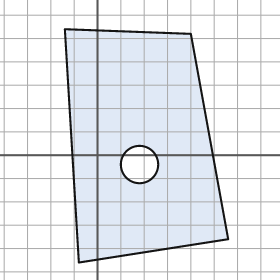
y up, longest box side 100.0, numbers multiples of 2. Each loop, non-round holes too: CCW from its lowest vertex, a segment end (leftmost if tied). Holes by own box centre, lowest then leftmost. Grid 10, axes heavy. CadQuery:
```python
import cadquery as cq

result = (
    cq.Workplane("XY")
    .moveTo(-8.0, -46.0)
    .lineTo(56.0, -36.0)
    .lineTo(40.0, 52.0)
    .lineTo(-14.0, 54.0)
    .close()
    .moveTo(18.0, -4.0)
    .circle(8.0)
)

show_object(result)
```